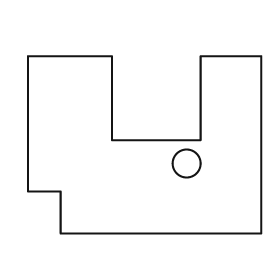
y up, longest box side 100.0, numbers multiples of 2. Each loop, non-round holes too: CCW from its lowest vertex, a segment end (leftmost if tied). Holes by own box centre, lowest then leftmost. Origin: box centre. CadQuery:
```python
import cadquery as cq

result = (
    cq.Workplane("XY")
    .moveTo(-36.0, -38.0)
    .lineTo(50.0, -38.0)
    .lineTo(50.0, 38.0)
    .lineTo(24.0, 38.0)
    .lineTo(24.0, 2.0)
    .lineTo(-14.0, 2.0)
    .lineTo(-14.0, 38.0)
    .lineTo(-50.0, 38.0)
    .lineTo(-50.0, -20.0)
    .lineTo(-36.0, -20.0)
    .close()
    .moveTo(18.0, -8.0)
    .circle(6.0)
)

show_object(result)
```